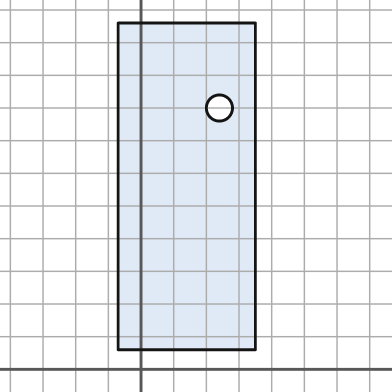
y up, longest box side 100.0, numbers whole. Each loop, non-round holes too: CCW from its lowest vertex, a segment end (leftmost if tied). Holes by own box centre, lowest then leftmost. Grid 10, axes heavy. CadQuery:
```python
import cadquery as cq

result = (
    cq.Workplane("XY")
    .moveTo(-7.0, 6.0)
    .lineTo(35.0, 6.0)
    .lineTo(35.0, 106.0)
    .lineTo(-7.0, 106.0)
    .close()
    .moveTo(24.0, 80.0)
    .circle(4.0)
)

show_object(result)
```